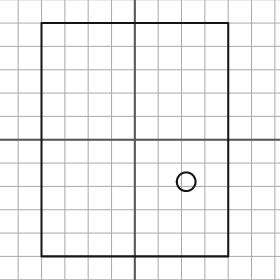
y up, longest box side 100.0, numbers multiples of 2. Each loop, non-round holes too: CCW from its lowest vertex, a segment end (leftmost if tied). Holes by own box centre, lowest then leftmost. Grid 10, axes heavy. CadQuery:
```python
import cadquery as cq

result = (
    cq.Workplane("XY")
    .moveTo(-40.0, -50.0)
    .lineTo(40.0, -50.0)
    .lineTo(40.0, 50.0)
    .lineTo(-40.0, 50.0)
    .close()
    .moveTo(22.0, -18.0)
    .circle(4.0)
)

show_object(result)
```